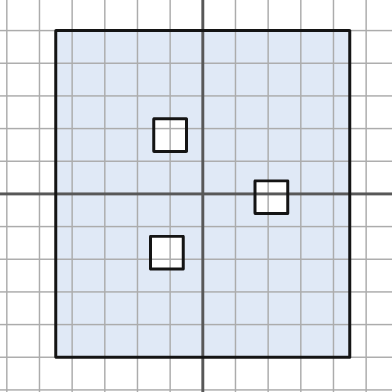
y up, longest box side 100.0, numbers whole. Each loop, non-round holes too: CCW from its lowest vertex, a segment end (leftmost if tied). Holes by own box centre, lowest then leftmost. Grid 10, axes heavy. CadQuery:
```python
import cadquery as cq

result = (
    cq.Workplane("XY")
    .moveTo(-45.0, -50.0)
    .lineTo(45.0, -50.0)
    .lineTo(45.0, 50.0)
    .lineTo(-45.0, 50.0)
    .close()
    .moveTo(-16.0, -23.0)
    .lineTo(-6.0, -23.0)
    .lineTo(-6.0, -13.0)
    .lineTo(-16.0, -13.0)
    .close()
    .moveTo(16.0, -6.0)
    .lineTo(26.0, -6.0)
    .lineTo(26.0, 4.0)
    .lineTo(16.0, 4.0)
    .close()
    .moveTo(-15.0, 13.0)
    .lineTo(-5.0, 13.0)
    .lineTo(-5.0, 23.0)
    .lineTo(-15.0, 23.0)
    .close()
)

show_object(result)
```